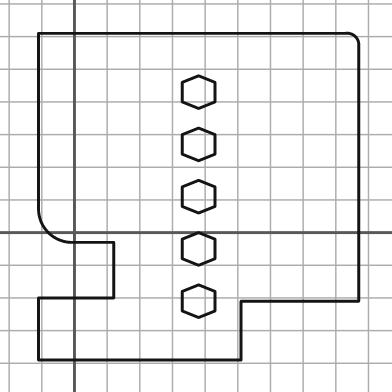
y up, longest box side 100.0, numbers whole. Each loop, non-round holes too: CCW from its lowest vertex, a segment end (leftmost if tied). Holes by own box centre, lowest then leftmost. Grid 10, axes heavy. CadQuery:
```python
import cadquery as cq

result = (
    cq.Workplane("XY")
    .moveTo(-11.0, -39.0)
    .lineTo(51.0, -39.0)
    .lineTo(51.0, -21.0)
    .lineTo(87.0, -21.0)
    .lineTo(87.0, 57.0)
    .threePointArc((86.0, 60.0), (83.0, 61.0))
    .lineTo(-11.0, 61.0)
    .lineTo(-11.0, 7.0)
    .threePointArc((-8.0, 0.0), (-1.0, -3.0))
    .lineTo(12.0, -3.0)
    .lineTo(12.0, -20.0)
    .lineTo(-11.0, -20.0)
    .close()
    .moveTo(38.0, -26.0)
    .lineTo(43.0, -24.0)
    .lineTo(43.0, -18.0)
    .lineTo(38.0, -16.0)
    .lineTo(33.0, -18.0)
    .lineTo(33.0, -24.0)
    .close()
    .moveTo(38.0, -10.0)
    .lineTo(43.0, -8.0)
    .lineTo(43.0, -2.0)
    .lineTo(38.0, 0.0)
    .lineTo(33.0, -2.0)
    .lineTo(33.0, -8.0)
    .close()
    .moveTo(38.0, 6.0)
    .lineTo(43.0, 8.0)
    .lineTo(43.0, 14.0)
    .lineTo(38.0, 16.0)
    .lineTo(33.0, 14.0)
    .lineTo(33.0, 8.0)
    .close()
    .moveTo(38.0, 22.0)
    .lineTo(43.0, 24.0)
    .lineTo(43.0, 30.0)
    .lineTo(38.0, 32.0)
    .lineTo(33.0, 30.0)
    .lineTo(33.0, 24.0)
    .close()
    .moveTo(38.0, 38.0)
    .lineTo(43.0, 40.0)
    .lineTo(43.0, 46.0)
    .lineTo(38.0, 48.0)
    .lineTo(33.0, 46.0)
    .lineTo(33.0, 40.0)
    .close()
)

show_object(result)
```